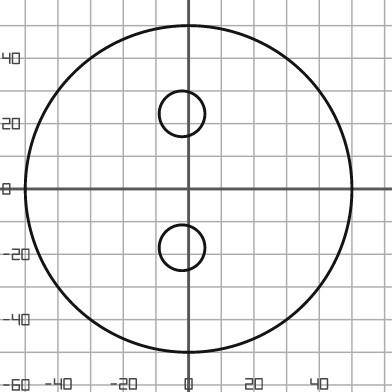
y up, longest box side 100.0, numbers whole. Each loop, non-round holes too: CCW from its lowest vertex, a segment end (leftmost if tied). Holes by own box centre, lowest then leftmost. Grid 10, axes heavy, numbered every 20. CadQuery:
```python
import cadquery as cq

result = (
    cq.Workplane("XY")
    .moveTo(0.0, 0.0)
    .circle(50.0)
    .moveTo(-2.0, -18.0)
    .circle(7.0)
    .moveTo(-2.0, 23.0)
    .circle(7.0)
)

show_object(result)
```